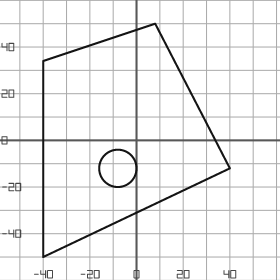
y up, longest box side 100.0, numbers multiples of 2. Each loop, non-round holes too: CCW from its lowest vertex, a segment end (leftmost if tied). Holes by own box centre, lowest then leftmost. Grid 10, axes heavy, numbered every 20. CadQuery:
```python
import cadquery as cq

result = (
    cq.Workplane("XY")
    .moveTo(-40.0, -50.0)
    .lineTo(40.0, -12.0)
    .lineTo(8.0, 50.0)
    .lineTo(-40.0, 34.0)
    .close()
    .moveTo(-8.0, -12.0)
    .circle(8.0)
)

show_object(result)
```